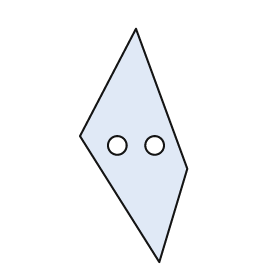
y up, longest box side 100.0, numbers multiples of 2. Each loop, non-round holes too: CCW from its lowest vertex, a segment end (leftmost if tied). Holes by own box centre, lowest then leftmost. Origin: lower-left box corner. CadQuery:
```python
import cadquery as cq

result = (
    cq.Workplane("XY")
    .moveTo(34.0, 0.0)
    .lineTo(46.0, 40.0)
    .lineTo(24.0, 100.0)
    .lineTo(0.0, 54.0)
    .close()
    .moveTo(16.0, 50.0)
    .circle(4.0)
    .moveTo(32.0, 50.0)
    .circle(4.0)
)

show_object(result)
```